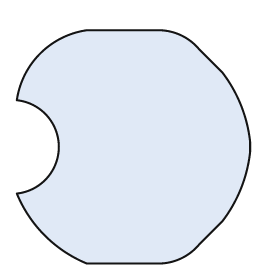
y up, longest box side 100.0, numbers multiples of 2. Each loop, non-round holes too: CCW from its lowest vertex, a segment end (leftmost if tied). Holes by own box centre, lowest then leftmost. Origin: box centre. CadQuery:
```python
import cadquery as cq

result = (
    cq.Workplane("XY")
    .moveTo(-20.0, -50.0)
    .lineTo(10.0, -50.0)
    .threePointArc((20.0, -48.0), (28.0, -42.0))
    .lineTo(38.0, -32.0)
    .threePointArc((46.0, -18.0), (50.0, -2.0))
    .lineTo(50.0, 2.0)
    .threePointArc((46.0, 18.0), (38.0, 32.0))
    .lineTo(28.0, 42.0)
    .threePointArc((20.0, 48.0), (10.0, 50.0))
    .lineTo(-20.0, 50.0)
    .threePointArc((-40.0, 40.0), (-50.0, 20.0))
    .threePointArc((-32.0, 0.0), (-50.0, -20.0))
    .threePointArc((-38.0, -38.0), (-20.0, -50.0))
    .close()
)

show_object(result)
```